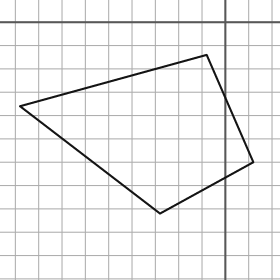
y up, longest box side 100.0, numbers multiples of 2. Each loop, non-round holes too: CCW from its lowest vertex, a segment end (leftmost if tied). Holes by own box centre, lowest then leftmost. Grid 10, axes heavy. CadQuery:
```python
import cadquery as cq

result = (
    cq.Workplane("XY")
    .moveTo(-28.0, -82.0)
    .lineTo(12.0, -60.0)
    .lineTo(-8.0, -14.0)
    .lineTo(-88.0, -36.0)
    .close()
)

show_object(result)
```